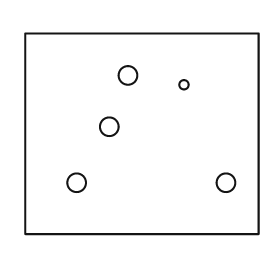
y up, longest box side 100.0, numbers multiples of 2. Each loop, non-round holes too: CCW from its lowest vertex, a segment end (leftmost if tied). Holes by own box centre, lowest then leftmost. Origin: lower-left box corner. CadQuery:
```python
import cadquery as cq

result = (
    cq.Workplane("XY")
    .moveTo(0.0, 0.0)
    .lineTo(100.0, 0.0)
    .lineTo(100.0, 86.0)
    .lineTo(0.0, 86.0)
    .close()
    .moveTo(22.0, 22.0)
    .circle(4.0)
    .moveTo(86.0, 22.0)
    .circle(4.0)
    .moveTo(36.0, 46.0)
    .circle(4.0)
    .moveTo(68.0, 64.0)
    .circle(2.0)
    .moveTo(44.0, 68.0)
    .circle(4.0)
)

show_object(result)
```